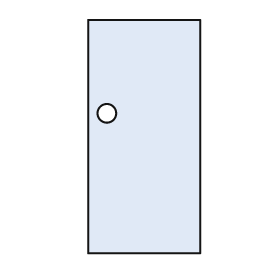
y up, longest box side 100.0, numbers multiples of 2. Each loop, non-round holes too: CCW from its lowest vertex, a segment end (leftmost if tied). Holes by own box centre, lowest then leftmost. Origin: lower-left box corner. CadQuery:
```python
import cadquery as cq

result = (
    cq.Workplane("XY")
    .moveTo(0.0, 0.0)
    .lineTo(48.0, 0.0)
    .lineTo(48.0, 100.0)
    .lineTo(0.0, 100.0)
    .close()
    .moveTo(8.0, 60.0)
    .circle(4.0)
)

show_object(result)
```